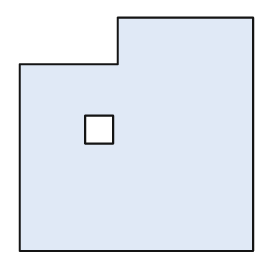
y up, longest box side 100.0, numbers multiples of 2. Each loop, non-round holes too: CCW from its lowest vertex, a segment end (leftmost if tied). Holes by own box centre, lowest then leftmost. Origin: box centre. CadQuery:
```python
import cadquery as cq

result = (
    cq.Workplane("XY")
    .moveTo(-50.0, -50.0)
    .lineTo(50.0, -50.0)
    .lineTo(50.0, 50.0)
    .lineTo(-8.0, 50.0)
    .lineTo(-8.0, 30.0)
    .lineTo(-50.0, 30.0)
    .close()
    .moveTo(-22.0, -4.0)
    .lineTo(-10.0, -4.0)
    .lineTo(-10.0, 8.0)
    .lineTo(-22.0, 8.0)
    .close()
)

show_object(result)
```